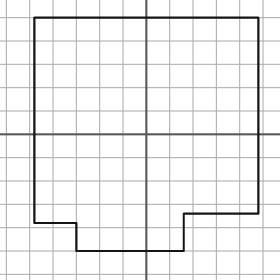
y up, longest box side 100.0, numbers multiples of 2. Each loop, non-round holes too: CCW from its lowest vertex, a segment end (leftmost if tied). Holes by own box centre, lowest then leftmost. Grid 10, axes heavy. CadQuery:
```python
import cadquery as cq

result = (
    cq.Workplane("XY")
    .moveTo(-30.0, -50.0)
    .lineTo(16.0, -50.0)
    .lineTo(16.0, -34.0)
    .lineTo(48.0, -34.0)
    .lineTo(48.0, 50.0)
    .lineTo(-48.0, 50.0)
    .lineTo(-48.0, -38.0)
    .lineTo(-30.0, -38.0)
    .close()
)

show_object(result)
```